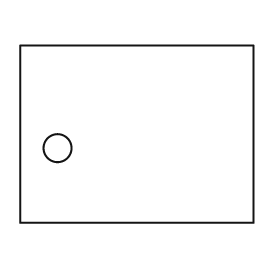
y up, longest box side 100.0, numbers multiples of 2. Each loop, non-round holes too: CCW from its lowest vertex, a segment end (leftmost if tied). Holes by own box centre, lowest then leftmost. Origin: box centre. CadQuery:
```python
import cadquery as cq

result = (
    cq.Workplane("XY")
    .moveTo(-50.0, -38.0)
    .lineTo(50.0, -38.0)
    .lineTo(50.0, 38.0)
    .lineTo(-50.0, 38.0)
    .close()
    .moveTo(-34.0, -6.0)
    .circle(6.0)
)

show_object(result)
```